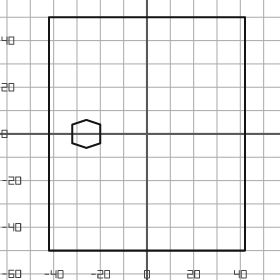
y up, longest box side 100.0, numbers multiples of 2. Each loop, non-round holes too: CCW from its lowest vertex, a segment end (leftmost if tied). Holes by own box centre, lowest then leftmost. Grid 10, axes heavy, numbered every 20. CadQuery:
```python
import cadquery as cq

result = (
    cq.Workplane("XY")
    .moveTo(-42.0, -50.0)
    .lineTo(42.0, -50.0)
    .lineTo(42.0, 50.0)
    .lineTo(-42.0, 50.0)
    .close()
    .moveTo(-26.0, -6.0)
    .lineTo(-20.0, -4.0)
    .lineTo(-20.0, 4.0)
    .lineTo(-26.0, 6.0)
    .lineTo(-32.0, 4.0)
    .lineTo(-32.0, -4.0)
    .close()
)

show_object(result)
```